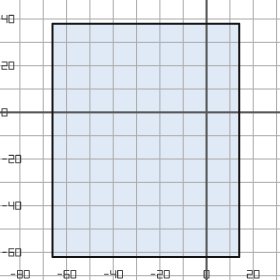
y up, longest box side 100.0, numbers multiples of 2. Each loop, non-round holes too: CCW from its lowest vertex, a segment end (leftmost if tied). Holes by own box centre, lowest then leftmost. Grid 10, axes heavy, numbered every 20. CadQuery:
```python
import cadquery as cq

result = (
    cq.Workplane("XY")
    .moveTo(-66.0, -62.0)
    .lineTo(14.0, -62.0)
    .lineTo(14.0, 38.0)
    .lineTo(-66.0, 38.0)
    .close()
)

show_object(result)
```